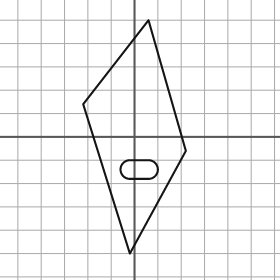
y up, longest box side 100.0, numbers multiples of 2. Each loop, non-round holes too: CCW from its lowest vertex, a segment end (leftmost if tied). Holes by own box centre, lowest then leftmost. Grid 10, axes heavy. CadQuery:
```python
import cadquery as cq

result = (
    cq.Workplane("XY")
    .moveTo(-2.0, -50.0)
    .lineTo(22.0, -6.0)
    .lineTo(6.0, 50.0)
    .lineTo(-22.0, 14.0)
    .close()
    .moveTo(-2.0, -18.0)
    .lineTo(6.0, -18.0)
    .threePointArc((10.0, -14.0), (6.0, -10.0))
    .lineTo(-2.0, -10.0)
    .threePointArc((-6.0, -14.0), (-2.0, -18.0))
    .close()
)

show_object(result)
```